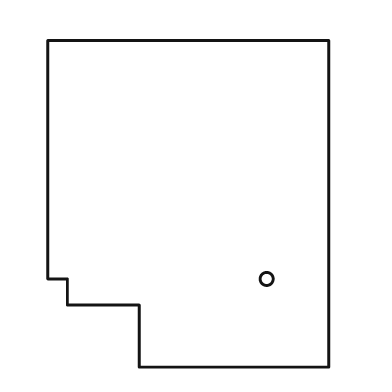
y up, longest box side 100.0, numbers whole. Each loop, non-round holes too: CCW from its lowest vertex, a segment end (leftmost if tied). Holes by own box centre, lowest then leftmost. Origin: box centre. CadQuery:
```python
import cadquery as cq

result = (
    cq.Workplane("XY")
    .moveTo(-15.0, -50.0)
    .lineTo(43.0, -50.0)
    .lineTo(43.0, 50.0)
    .lineTo(-43.0, 50.0)
    .lineTo(-43.0, -23.0)
    .lineTo(-37.0, -23.0)
    .lineTo(-37.0, -31.0)
    .lineTo(-15.0, -31.0)
    .close()
    .moveTo(24.0, -23.0)
    .circle(2.0)
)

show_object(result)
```